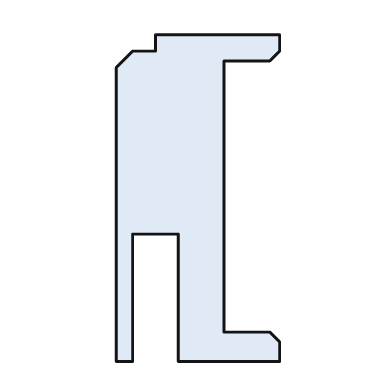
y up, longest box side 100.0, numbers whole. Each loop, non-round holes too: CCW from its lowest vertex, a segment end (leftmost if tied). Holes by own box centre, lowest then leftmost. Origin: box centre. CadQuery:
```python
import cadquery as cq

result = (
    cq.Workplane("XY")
    .moveTo(-25.0, -50.0)
    .lineTo(-20.0, -50.0)
    .lineTo(-20.0, -11.0)
    .lineTo(-6.0, -11.0)
    .lineTo(-6.0, -50.0)
    .lineTo(25.0, -50.0)
    .lineTo(25.0, -44.0)
    .lineTo(22.0, -41.0)
    .lineTo(8.0, -41.0)
    .lineTo(8.0, 42.0)
    .lineTo(22.0, 42.0)
    .lineTo(25.0, 45.0)
    .lineTo(25.0, 50.0)
    .lineTo(-13.0, 50.0)
    .lineTo(-13.0, 45.0)
    .lineTo(-20.0, 45.0)
    .lineTo(-25.0, 40.0)
    .close()
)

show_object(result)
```